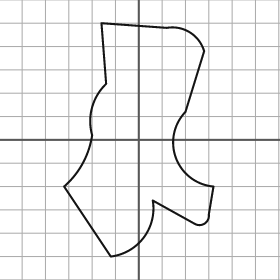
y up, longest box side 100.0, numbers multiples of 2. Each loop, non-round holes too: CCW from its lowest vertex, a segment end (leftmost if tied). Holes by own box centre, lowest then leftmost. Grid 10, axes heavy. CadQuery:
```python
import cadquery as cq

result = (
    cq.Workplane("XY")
    .moveTo(-12.0, -50.0)
    .threePointArc((2.0, -42.0), (6.0, -26.0))
    .lineTo(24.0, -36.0)
    .threePointArc((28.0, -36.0), (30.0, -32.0))
    .lineTo(32.0, -20.0)
    .threePointArc((16.0, -8.0), (20.0, 12.0))
    .lineTo(28.0, 38.0)
    .threePointArc((22.0, 46.0), (12.0, 48.0))
    .lineTo(-16.0, 50.0)
    .lineTo(-14.0, 24.0)
    .threePointArc((-20.0, 14.0), (-20.0, 2.0))
    .threePointArc((-24.0, -10.0), (-32.0, -20.0))
    .close()
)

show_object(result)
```